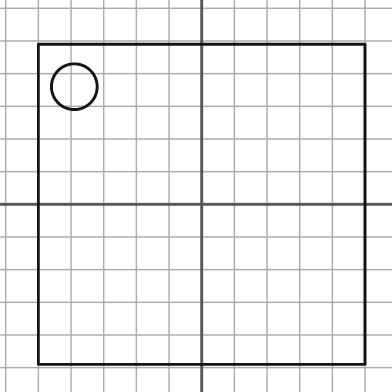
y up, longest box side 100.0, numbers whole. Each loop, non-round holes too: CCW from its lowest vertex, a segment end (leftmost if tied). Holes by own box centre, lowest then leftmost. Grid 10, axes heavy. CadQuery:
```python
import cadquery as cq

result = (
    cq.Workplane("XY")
    .moveTo(-50.0, -49.0)
    .lineTo(50.0, -49.0)
    .lineTo(50.0, 49.0)
    .lineTo(-50.0, 49.0)
    .close()
    .moveTo(-39.0, 36.0)
    .circle(7.0)
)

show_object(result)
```